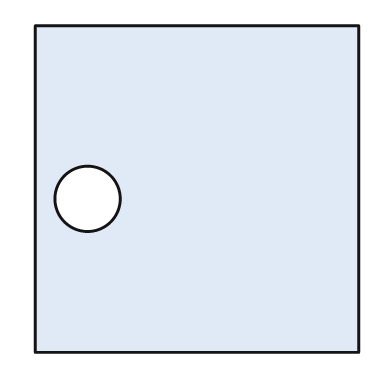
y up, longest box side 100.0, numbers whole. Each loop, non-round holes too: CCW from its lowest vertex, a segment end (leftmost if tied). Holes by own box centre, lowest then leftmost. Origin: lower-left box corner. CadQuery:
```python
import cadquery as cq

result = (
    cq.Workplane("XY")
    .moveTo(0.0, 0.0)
    .lineTo(99.0, 0.0)
    .lineTo(99.0, 100.0)
    .lineTo(0.0, 100.0)
    .close()
    .moveTo(16.0, 47.0)
    .circle(10.0)
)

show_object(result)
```